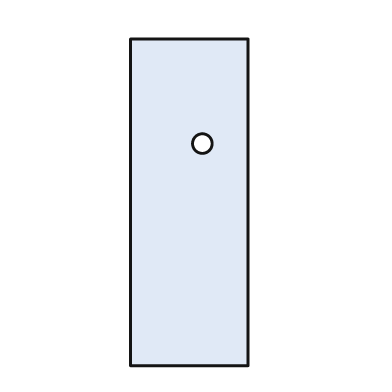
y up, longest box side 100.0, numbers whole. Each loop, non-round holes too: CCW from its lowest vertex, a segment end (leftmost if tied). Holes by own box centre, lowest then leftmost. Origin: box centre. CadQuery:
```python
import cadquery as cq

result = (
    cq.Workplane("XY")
    .moveTo(-18.0, -50.0)
    .lineTo(18.0, -50.0)
    .lineTo(18.0, 50.0)
    .lineTo(-18.0, 50.0)
    .close()
    .moveTo(4.0, 18.0)
    .circle(3.0)
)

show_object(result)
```